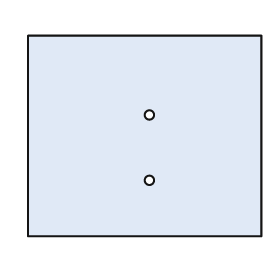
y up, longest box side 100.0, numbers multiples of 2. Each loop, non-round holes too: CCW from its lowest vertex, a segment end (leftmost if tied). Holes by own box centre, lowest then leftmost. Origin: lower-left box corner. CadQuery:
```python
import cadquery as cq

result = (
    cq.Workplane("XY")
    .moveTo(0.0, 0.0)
    .lineTo(100.0, 0.0)
    .lineTo(100.0, 86.0)
    .lineTo(0.0, 86.0)
    .close()
    .moveTo(52.0, 24.0)
    .circle(2.0)
    .moveTo(52.0, 52.0)
    .circle(2.0)
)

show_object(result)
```